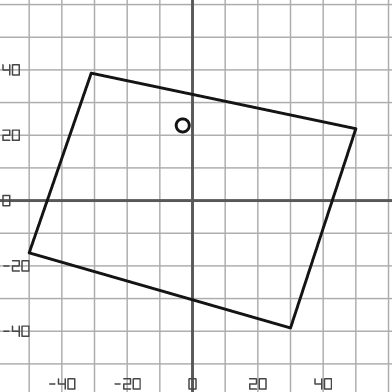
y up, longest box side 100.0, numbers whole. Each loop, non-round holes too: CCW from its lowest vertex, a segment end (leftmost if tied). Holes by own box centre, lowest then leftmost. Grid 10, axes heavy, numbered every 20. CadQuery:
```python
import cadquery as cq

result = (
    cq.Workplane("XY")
    .moveTo(30.0, -39.0)
    .lineTo(50.0, 22.0)
    .lineTo(-31.0, 39.0)
    .lineTo(-50.0, -16.0)
    .close()
    .moveTo(-3.0, 23.0)
    .circle(2.0)
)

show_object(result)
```